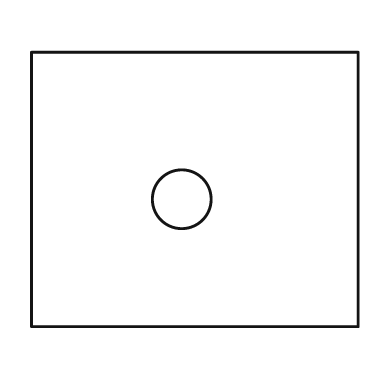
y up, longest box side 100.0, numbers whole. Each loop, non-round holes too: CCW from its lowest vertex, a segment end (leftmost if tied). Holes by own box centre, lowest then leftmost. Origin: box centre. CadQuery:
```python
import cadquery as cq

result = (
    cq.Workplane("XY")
    .moveTo(-50.0, -42.0)
    .lineTo(50.0, -42.0)
    .lineTo(50.0, 42.0)
    .lineTo(-50.0, 42.0)
    .close()
    .moveTo(-4.0, -3.0)
    .circle(9.0)
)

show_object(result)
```